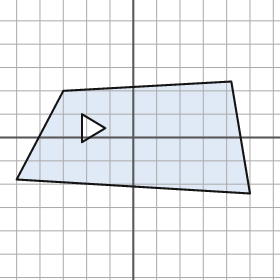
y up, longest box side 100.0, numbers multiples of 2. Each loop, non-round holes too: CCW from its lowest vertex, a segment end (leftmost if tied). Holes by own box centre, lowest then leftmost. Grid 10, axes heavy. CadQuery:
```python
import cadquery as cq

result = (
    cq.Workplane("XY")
    .moveTo(50.0, -24.0)
    .lineTo(42.0, 24.0)
    .lineTo(-30.0, 20.0)
    .lineTo(-50.0, -18.0)
    .close()
    .moveTo(-22.0, -2.0)
    .lineTo(-12.0, 4.0)
    .lineTo(-22.0, 10.0)
    .close()
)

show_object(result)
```